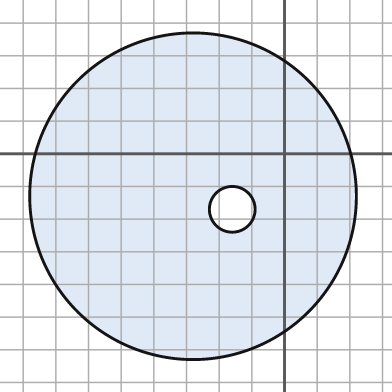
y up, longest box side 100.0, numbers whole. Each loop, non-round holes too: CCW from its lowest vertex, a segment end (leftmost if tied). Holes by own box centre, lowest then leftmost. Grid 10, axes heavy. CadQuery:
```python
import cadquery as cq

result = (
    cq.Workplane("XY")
    .moveTo(-28.0, -13.0)
    .circle(50.0)
    .moveTo(-16.0, -17.0)
    .circle(7.0)
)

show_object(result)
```